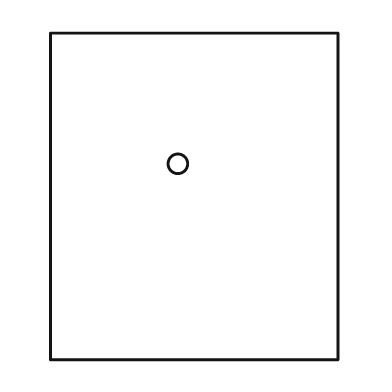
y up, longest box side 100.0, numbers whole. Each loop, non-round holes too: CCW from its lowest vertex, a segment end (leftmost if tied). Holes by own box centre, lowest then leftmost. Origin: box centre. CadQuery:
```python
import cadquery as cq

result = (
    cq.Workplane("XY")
    .moveTo(-44.0, -50.0)
    .lineTo(44.0, -50.0)
    .lineTo(44.0, 50.0)
    .lineTo(-44.0, 50.0)
    .close()
    .moveTo(-5.0, 10.0)
    .circle(3.0)
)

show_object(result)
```